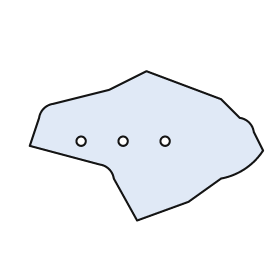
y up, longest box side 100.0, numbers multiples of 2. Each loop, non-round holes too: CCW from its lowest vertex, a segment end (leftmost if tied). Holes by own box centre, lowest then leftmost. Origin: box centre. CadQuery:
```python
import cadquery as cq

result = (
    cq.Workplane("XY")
    .moveTo(-4.0, -32.0)
    .lineTo(18.0, -24.0)
    .lineTo(32.0, -14.0)
    .threePointArc((42.0, -10.0), (50.0, -2.0))
    .lineTo(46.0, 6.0)
    .threePointArc((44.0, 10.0), (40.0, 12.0))
    .lineTo(32.0, 20.0)
    .lineTo(0.0, 32.0)
    .lineTo(-16.0, 24.0)
    .lineTo(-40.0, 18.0)
    .threePointArc((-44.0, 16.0), (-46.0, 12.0))
    .lineTo(-50.0, 0.0)
    .lineTo(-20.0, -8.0)
    .threePointArc((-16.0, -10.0), (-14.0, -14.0))
    .close()
    .moveTo(-28.0, 2.0)
    .circle(2.0)
    .moveTo(-10.0, 2.0)
    .circle(2.0)
    .moveTo(8.0, 2.0)
    .circle(2.0)
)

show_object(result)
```